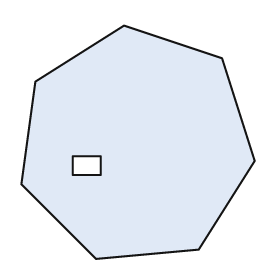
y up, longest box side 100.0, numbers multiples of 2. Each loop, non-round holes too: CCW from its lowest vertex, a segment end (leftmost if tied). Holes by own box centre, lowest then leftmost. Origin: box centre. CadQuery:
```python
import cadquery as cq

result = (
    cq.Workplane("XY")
    .moveTo(-18.0, -50.0)
    .lineTo(26.0, -46.0)
    .lineTo(50.0, -8.0)
    .lineTo(36.0, 36.0)
    .lineTo(-6.0, 50.0)
    .lineTo(-44.0, 26.0)
    .lineTo(-50.0, -18.0)
    .close()
    .moveTo(-28.0, -14.0)
    .lineTo(-16.0, -14.0)
    .lineTo(-16.0, -6.0)
    .lineTo(-28.0, -6.0)
    .close()
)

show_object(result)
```